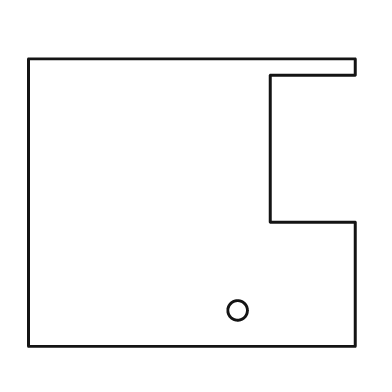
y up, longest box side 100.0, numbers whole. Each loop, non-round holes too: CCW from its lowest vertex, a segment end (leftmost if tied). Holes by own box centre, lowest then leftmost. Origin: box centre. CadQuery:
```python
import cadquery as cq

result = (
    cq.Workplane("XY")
    .moveTo(-50.0, -44.0)
    .lineTo(50.0, -44.0)
    .lineTo(50.0, -6.0)
    .lineTo(24.0, -6.0)
    .lineTo(24.0, 39.0)
    .lineTo(50.0, 39.0)
    .lineTo(50.0, 44.0)
    .lineTo(-50.0, 44.0)
    .close()
    .moveTo(14.0, -33.0)
    .circle(3.0)
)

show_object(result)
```